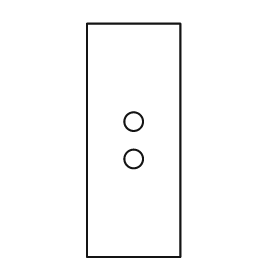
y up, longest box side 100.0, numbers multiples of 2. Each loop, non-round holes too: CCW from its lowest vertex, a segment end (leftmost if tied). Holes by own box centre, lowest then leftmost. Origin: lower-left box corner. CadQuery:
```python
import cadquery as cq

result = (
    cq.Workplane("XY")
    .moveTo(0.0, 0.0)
    .lineTo(40.0, 0.0)
    .lineTo(40.0, 100.0)
    .lineTo(0.0, 100.0)
    .close()
    .moveTo(20.0, 42.0)
    .circle(4.0)
    .moveTo(20.0, 58.0)
    .circle(4.0)
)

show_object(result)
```